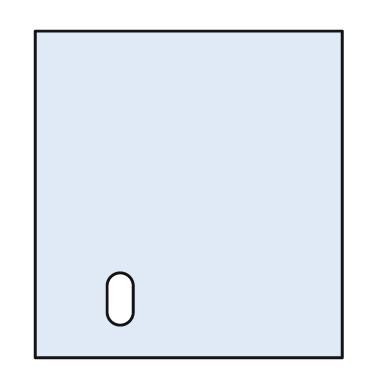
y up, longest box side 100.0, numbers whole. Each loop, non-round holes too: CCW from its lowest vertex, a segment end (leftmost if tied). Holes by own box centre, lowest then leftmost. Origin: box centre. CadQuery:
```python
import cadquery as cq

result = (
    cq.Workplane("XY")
    .moveTo(-47.0, -50.0)
    .lineTo(47.0, -50.0)
    .lineTo(47.0, 50.0)
    .lineTo(-47.0, 50.0)
    .close()
    .moveTo(-25.0, -36.0)
    .threePointArc((-21.0, -40.0), (-17.0, -36.0))
    .lineTo(-17.0, -28.0)
    .threePointArc((-21.0, -24.0), (-25.0, -28.0))
    .close()
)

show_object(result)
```